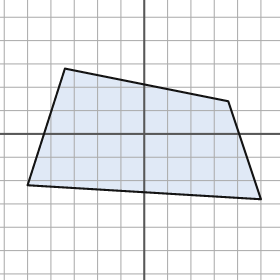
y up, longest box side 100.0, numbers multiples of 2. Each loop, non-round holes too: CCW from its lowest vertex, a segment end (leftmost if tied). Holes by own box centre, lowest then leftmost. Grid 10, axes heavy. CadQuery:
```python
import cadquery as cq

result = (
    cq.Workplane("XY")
    .moveTo(50.0, -28.0)
    .lineTo(36.0, 14.0)
    .lineTo(-34.0, 28.0)
    .lineTo(-50.0, -22.0)
    .close()
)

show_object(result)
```